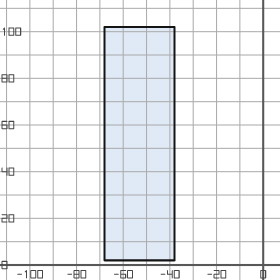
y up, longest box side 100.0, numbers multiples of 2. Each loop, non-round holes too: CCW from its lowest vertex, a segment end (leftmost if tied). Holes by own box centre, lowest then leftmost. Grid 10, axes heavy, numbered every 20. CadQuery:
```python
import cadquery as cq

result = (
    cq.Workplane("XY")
    .moveTo(-68.0, 2.0)
    .lineTo(-38.0, 2.0)
    .lineTo(-38.0, 102.0)
    .lineTo(-68.0, 102.0)
    .close()
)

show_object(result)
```